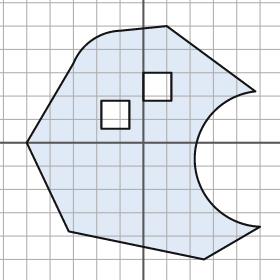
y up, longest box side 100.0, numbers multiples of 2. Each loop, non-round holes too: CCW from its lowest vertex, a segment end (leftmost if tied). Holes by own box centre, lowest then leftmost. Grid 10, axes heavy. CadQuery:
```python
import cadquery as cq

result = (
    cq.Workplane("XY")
    .moveTo(26.0, -50.0)
    .lineTo(50.0, -36.0)
    .threePointArc((22.0, -8.0), (48.0, 22.0))
    .lineTo(10.0, 50.0)
    .lineTo(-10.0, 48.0)
    .threePointArc((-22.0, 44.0), (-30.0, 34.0))
    .lineTo(-50.0, 0.0)
    .lineTo(-32.0, -38.0)
    .close()
    .moveTo(-18.0, 6.0)
    .lineTo(-6.0, 6.0)
    .lineTo(-6.0, 18.0)
    .lineTo(-18.0, 18.0)
    .close()
    .moveTo(0.0, 18.0)
    .lineTo(12.0, 18.0)
    .lineTo(12.0, 30.0)
    .lineTo(0.0, 30.0)
    .close()
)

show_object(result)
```